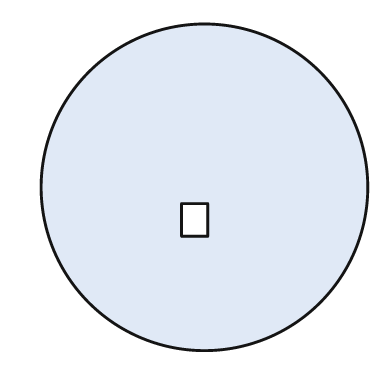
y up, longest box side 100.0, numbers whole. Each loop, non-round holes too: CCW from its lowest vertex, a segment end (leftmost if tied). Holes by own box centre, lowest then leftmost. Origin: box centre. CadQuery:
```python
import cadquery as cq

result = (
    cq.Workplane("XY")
    .moveTo(0.0, 0.0)
    .circle(50.0)
    .moveTo(-7.0, -15.0)
    .lineTo(1.0, -15.0)
    .lineTo(1.0, -5.0)
    .lineTo(-7.0, -5.0)
    .close()
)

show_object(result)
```